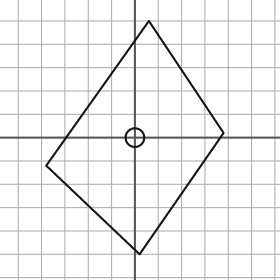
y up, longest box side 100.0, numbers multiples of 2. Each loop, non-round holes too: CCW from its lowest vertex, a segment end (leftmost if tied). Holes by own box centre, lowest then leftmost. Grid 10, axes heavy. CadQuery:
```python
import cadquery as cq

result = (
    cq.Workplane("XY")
    .moveTo(2.0, -50.0)
    .lineTo(38.0, 2.0)
    .lineTo(6.0, 50.0)
    .lineTo(-38.0, -12.0)
    .close()
    .moveTo(0.0, 0.0)
    .circle(4.0)
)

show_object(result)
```